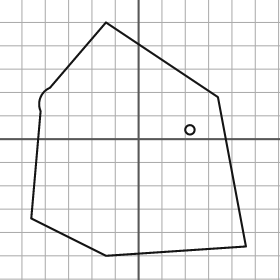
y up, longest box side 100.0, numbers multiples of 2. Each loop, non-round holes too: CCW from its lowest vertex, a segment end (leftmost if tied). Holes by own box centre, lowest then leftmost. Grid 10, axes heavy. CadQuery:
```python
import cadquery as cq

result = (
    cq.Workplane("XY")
    .moveTo(-14.0, -50.0)
    .lineTo(46.0, -46.0)
    .lineTo(34.0, 18.0)
    .lineTo(-14.0, 50.0)
    .lineTo(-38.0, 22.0)
    .threePointArc((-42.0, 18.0), (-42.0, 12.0))
    .lineTo(-46.0, -34.0)
    .close()
    .moveTo(22.0, 4.0)
    .circle(2.0)
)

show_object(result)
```